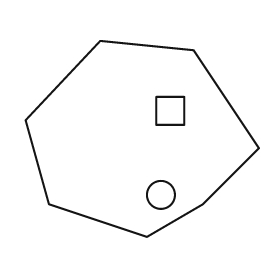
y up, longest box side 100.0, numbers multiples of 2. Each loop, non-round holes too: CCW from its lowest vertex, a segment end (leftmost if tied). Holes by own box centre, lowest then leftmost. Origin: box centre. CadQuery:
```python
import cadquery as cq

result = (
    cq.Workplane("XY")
    .moveTo(2.0, -42.0)
    .lineTo(26.0, -28.0)
    .lineTo(50.0, -4.0)
    .lineTo(22.0, 38.0)
    .lineTo(-18.0, 42.0)
    .lineTo(-50.0, 8.0)
    .lineTo(-40.0, -28.0)
    .close()
    .moveTo(8.0, -24.0)
    .circle(6.0)
    .moveTo(6.0, 6.0)
    .lineTo(18.0, 6.0)
    .lineTo(18.0, 18.0)
    .lineTo(6.0, 18.0)
    .close()
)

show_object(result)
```